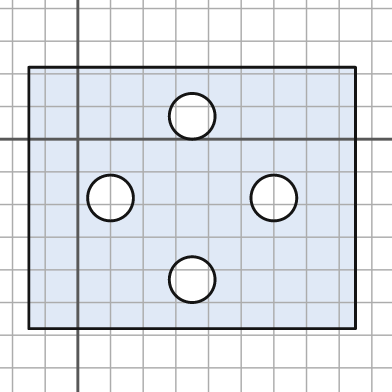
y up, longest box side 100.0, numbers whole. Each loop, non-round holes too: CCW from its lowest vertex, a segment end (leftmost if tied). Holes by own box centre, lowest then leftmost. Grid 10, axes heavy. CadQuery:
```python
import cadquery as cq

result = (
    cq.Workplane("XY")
    .moveTo(-15.0, -58.0)
    .lineTo(85.0, -58.0)
    .lineTo(85.0, 22.0)
    .lineTo(-15.0, 22.0)
    .close()
    .moveTo(35.0, -43.0)
    .circle(7.0)
    .moveTo(10.0, -18.0)
    .circle(7.0)
    .moveTo(60.0, -18.0)
    .circle(7.0)
    .moveTo(35.0, 7.0)
    .circle(7.0)
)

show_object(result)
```